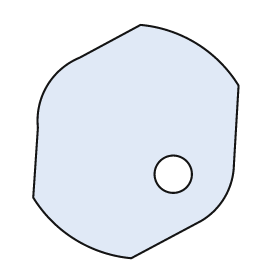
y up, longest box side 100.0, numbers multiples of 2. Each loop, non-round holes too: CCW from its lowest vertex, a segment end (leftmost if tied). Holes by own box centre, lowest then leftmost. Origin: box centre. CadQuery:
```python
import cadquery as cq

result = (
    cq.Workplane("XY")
    .moveTo(-2.0, -50.0)
    .lineTo(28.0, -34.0)
    .threePointArc((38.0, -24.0), (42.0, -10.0))
    .lineTo(44.0, 24.0)
    .threePointArc((26.0, 42.0), (2.0, 50.0))
    .lineTo(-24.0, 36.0)
    .threePointArc((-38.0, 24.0), (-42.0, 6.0))
    .lineTo(-44.0, -24.0)
    .threePointArc((-26.0, -42.0), (-2.0, -50.0))
    .close()
    .moveTo(16.0, -14.0)
    .circle(8.0)
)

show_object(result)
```